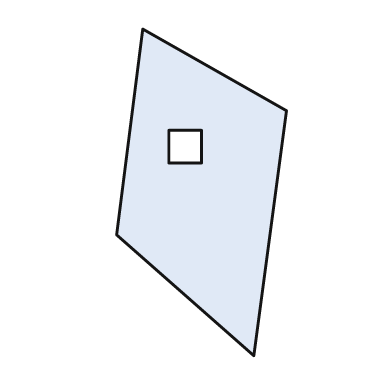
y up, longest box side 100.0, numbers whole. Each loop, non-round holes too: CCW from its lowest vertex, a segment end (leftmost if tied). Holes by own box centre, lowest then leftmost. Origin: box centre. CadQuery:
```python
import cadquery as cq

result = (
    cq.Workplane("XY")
    .moveTo(16.0, -50.0)
    .lineTo(26.0, 25.0)
    .lineTo(-18.0, 50.0)
    .lineTo(-26.0, -13.0)
    .close()
    .moveTo(-10.0, 9.0)
    .lineTo(0.0, 9.0)
    .lineTo(0.0, 19.0)
    .lineTo(-10.0, 19.0)
    .close()
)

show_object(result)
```